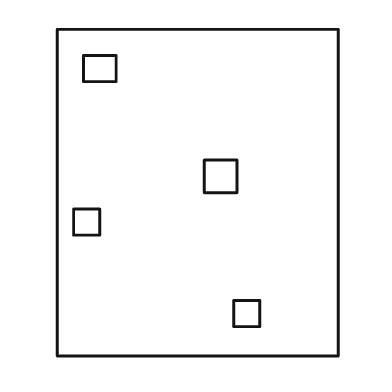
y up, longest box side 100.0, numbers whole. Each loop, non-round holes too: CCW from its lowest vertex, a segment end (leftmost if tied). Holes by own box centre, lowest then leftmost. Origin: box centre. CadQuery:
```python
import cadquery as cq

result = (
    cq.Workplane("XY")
    .moveTo(-43.0, -50.0)
    .lineTo(43.0, -50.0)
    .lineTo(43.0, 50.0)
    .lineTo(-43.0, 50.0)
    .close()
    .moveTo(11.0, -41.0)
    .lineTo(19.0, -41.0)
    .lineTo(19.0, -33.0)
    .lineTo(11.0, -33.0)
    .close()
    .moveTo(-38.0, -13.0)
    .lineTo(-30.0, -13.0)
    .lineTo(-30.0, -5.0)
    .lineTo(-38.0, -5.0)
    .close()
    .moveTo(2.0, 0.0)
    .lineTo(12.0, 0.0)
    .lineTo(12.0, 10.0)
    .lineTo(2.0, 10.0)
    .close()
    .moveTo(-35.0, 34.0)
    .lineTo(-25.0, 34.0)
    .lineTo(-25.0, 42.0)
    .lineTo(-35.0, 42.0)
    .close()
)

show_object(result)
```